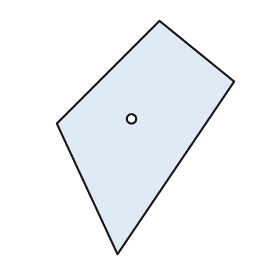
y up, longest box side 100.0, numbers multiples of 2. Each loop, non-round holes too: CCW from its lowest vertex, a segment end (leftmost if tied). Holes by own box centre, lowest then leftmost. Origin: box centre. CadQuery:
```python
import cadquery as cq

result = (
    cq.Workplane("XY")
    .moveTo(-12.0, -50.0)
    .lineTo(38.0, 24.0)
    .lineTo(6.0, 50.0)
    .lineTo(-38.0, 6.0)
    .close()
    .moveTo(-6.0, 8.0)
    .circle(2.0)
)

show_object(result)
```